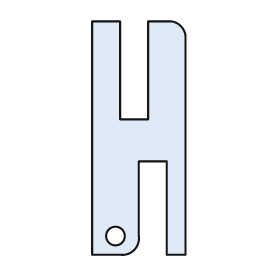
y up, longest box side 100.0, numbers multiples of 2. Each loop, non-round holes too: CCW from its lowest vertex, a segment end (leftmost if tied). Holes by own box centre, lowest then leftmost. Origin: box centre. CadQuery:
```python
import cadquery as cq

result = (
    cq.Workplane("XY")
    .moveTo(-20.0, -50.0)
    .lineTo(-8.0, -50.0)
    .threePointArc((-2.0, -48.0), (0.0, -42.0))
    .lineTo(0.0, -10.0)
    .lineTo(12.0, -10.0)
    .lineTo(12.0, -50.0)
    .lineTo(20.0, -50.0)
    .lineTo(20.0, 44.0)
    .threePointArc((18.0, 48.0), (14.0, 50.0))
    .lineTo(4.0, 50.0)
    .lineTo(4.0, 8.0)
    .lineTo(-8.0, 8.0)
    .lineTo(-8.0, 50.0)
    .lineTo(-20.0, 50.0)
    .close()
    .moveTo(-10.0, -42.0)
    .circle(4.0)
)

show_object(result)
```